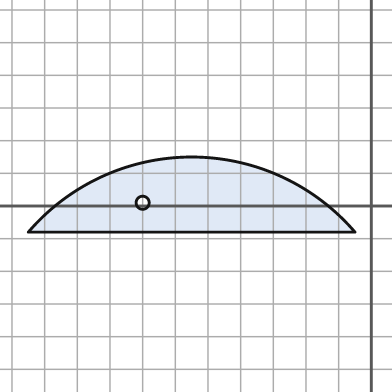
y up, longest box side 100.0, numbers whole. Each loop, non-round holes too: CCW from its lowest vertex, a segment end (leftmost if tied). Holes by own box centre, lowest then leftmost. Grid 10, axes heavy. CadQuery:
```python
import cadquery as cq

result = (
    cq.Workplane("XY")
    .moveTo(-105.0, -8.0)
    .lineTo(-5.0, -8.0)
    .threePointArc((-55.0, 15.0), (-105.0, -8.0))
    .close()
    .moveTo(-70.0, 1.0)
    .circle(2.0)
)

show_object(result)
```